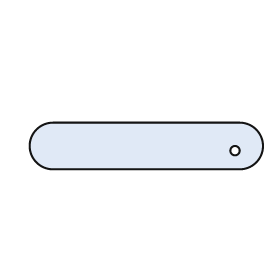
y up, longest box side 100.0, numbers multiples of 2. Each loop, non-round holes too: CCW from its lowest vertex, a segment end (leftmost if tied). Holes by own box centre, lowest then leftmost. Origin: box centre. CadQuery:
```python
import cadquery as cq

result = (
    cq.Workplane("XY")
    .moveTo(-40.0, -10.0)
    .lineTo(40.0, -10.0)
    .threePointArc((50.0, 0.0), (40.0, 10.0))
    .lineTo(-40.0, 10.0)
    .threePointArc((-50.0, 0.0), (-40.0, -10.0))
    .close()
    .moveTo(38.0, -2.0)
    .circle(2.0)
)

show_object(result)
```